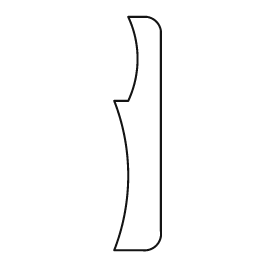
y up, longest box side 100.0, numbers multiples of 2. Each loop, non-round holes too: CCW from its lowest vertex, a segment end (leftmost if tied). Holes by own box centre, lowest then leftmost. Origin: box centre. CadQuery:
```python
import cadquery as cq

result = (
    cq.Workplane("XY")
    .moveTo(-10.0, -50.0)
    .lineTo(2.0, -50.0)
    .threePointArc((8.0, -48.0), (10.0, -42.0))
    .lineTo(10.0, 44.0)
    .threePointArc((8.0, 48.0), (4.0, 50.0))
    .lineTo(-4.0, 50.0)
    .threePointArc((0.0, 32.0), (-4.0, 14.0))
    .lineTo(-10.0, 14.0)
    .threePointArc((-4.0, -18.0), (-10.0, -50.0))
    .close()
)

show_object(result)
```